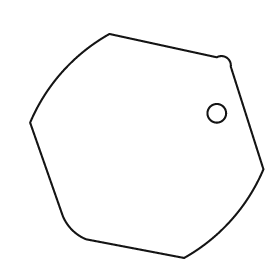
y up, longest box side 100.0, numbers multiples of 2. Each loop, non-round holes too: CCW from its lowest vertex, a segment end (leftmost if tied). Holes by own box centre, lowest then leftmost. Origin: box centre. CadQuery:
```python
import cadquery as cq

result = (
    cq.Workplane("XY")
    .moveTo(16.0, -48.0)
    .threePointArc((36.0, -32.0), (50.0, -10.0))
    .lineTo(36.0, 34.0)
    .threePointArc((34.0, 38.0), (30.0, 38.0))
    .lineTo(-16.0, 48.0)
    .threePointArc((-36.0, 32.0), (-50.0, 10.0))
    .lineTo(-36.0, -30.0)
    .threePointArc((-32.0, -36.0), (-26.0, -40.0))
    .close()
    .moveTo(30.0, 14.0)
    .circle(4.0)
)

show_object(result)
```